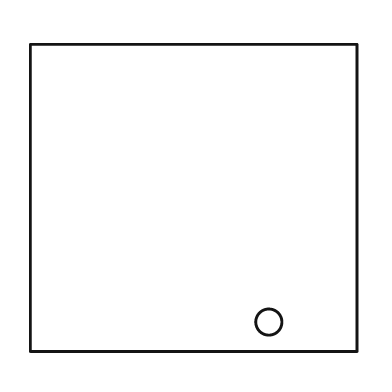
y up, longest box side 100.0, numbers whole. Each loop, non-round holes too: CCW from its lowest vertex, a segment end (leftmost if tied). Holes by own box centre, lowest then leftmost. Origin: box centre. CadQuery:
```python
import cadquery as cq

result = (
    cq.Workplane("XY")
    .moveTo(-50.0, -47.0)
    .lineTo(50.0, -47.0)
    .lineTo(50.0, 47.0)
    .lineTo(-50.0, 47.0)
    .close()
    .moveTo(23.0, -38.0)
    .circle(4.0)
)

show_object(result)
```